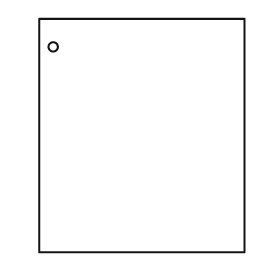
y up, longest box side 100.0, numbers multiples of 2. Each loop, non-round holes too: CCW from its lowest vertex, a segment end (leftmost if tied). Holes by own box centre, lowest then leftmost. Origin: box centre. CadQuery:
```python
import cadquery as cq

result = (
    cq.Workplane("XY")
    .moveTo(-44.0, -50.0)
    .lineTo(44.0, -50.0)
    .lineTo(44.0, 50.0)
    .lineTo(-44.0, 50.0)
    .close()
    .moveTo(-38.0, 38.0)
    .circle(2.0)
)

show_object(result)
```